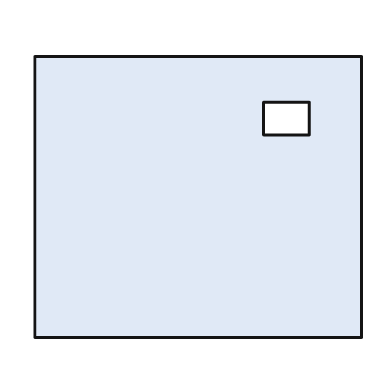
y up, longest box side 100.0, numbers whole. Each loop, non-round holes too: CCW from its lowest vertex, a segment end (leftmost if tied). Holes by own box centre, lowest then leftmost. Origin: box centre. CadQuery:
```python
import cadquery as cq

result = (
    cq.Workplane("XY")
    .moveTo(-50.0, -43.0)
    .lineTo(50.0, -43.0)
    .lineTo(50.0, 43.0)
    .lineTo(-50.0, 43.0)
    .close()
    .moveTo(20.0, 19.0)
    .lineTo(34.0, 19.0)
    .lineTo(34.0, 29.0)
    .lineTo(20.0, 29.0)
    .close()
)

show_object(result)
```